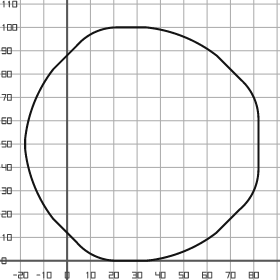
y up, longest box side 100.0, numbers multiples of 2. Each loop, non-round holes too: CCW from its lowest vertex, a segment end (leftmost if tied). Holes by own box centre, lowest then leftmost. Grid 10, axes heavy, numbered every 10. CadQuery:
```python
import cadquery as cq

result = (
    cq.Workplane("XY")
    .moveTo(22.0, 0.0)
    .lineTo(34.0, 0.0)
    .threePointArc((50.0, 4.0), (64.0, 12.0))
    .lineTo(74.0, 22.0)
    .threePointArc((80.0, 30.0), (82.0, 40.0))
    .lineTo(82.0, 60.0)
    .threePointArc((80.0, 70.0), (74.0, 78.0))
    .lineTo(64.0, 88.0)
    .threePointArc((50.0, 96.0), (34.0, 100.0))
    .lineTo(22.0, 100.0)
    .threePointArc((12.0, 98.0), (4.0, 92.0))
    .lineTo(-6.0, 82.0)
    .threePointArc((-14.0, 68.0), (-18.0, 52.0))
    .lineTo(-18.0, 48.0)
    .threePointArc((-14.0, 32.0), (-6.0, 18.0))
    .lineTo(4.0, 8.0)
    .threePointArc((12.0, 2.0), (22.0, 0.0))
    .close()
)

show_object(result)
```